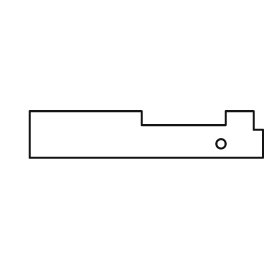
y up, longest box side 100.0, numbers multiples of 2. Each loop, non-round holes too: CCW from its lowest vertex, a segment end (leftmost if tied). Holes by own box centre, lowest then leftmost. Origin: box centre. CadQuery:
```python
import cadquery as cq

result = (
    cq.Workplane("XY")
    .moveTo(-50.0, -10.0)
    .lineTo(50.0, -10.0)
    .lineTo(50.0, 2.0)
    .lineTo(46.0, 2.0)
    .lineTo(46.0, 10.0)
    .lineTo(34.0, 10.0)
    .lineTo(34.0, 4.0)
    .lineTo(-2.0, 4.0)
    .lineTo(-2.0, 10.0)
    .lineTo(-50.0, 10.0)
    .close()
    .moveTo(32.0, -4.0)
    .circle(2.0)
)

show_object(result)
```